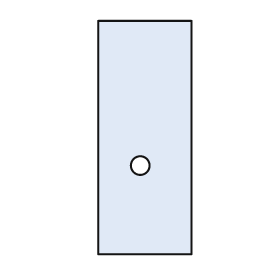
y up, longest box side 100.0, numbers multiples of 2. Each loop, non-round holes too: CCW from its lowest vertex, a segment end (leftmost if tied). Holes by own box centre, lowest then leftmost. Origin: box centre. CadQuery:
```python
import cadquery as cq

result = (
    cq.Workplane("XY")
    .moveTo(-20.0, -50.0)
    .lineTo(20.0, -50.0)
    .lineTo(20.0, 50.0)
    .lineTo(-20.0, 50.0)
    .close()
    .moveTo(-2.0, -12.0)
    .circle(4.0)
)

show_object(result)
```